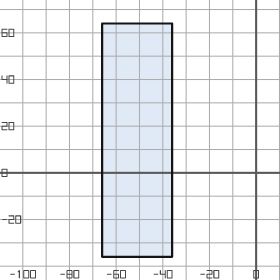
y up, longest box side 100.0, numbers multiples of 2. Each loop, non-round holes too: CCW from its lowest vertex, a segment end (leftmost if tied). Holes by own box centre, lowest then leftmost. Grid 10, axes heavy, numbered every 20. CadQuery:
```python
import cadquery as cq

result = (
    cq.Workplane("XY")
    .moveTo(-66.0, -36.0)
    .lineTo(-36.0, -36.0)
    .lineTo(-36.0, 64.0)
    .lineTo(-66.0, 64.0)
    .close()
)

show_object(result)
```